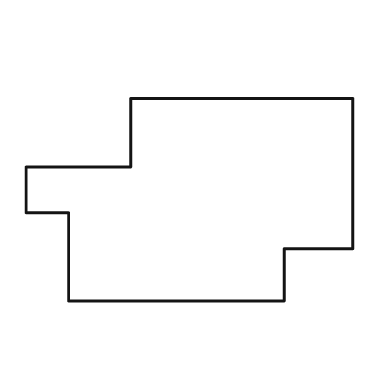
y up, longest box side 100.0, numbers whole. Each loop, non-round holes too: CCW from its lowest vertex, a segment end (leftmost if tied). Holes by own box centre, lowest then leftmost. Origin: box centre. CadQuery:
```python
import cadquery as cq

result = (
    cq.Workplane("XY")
    .moveTo(-37.0, -31.0)
    .lineTo(29.0, -31.0)
    .lineTo(29.0, -15.0)
    .lineTo(50.0, -15.0)
    .lineTo(50.0, 31.0)
    .lineTo(-18.0, 31.0)
    .lineTo(-18.0, 10.0)
    .lineTo(-50.0, 10.0)
    .lineTo(-50.0, -4.0)
    .lineTo(-37.0, -4.0)
    .close()
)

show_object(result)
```